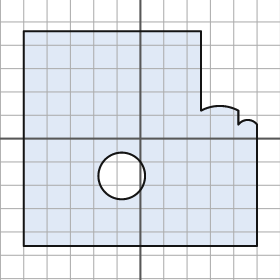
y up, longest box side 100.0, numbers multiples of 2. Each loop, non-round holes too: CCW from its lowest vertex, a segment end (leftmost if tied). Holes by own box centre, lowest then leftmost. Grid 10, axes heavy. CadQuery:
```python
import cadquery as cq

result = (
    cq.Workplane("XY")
    .moveTo(-50.0, -46.0)
    .lineTo(50.0, -46.0)
    .lineTo(50.0, 6.0)
    .threePointArc((46.0, 8.0), (42.0, 6.0))
    .lineTo(42.0, 12.0)
    .threePointArc((34.0, 14.0), (26.0, 12.0))
    .lineTo(26.0, 46.0)
    .lineTo(-50.0, 46.0)
    .close()
    .moveTo(-8.0, -16.0)
    .circle(10.0)
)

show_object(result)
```